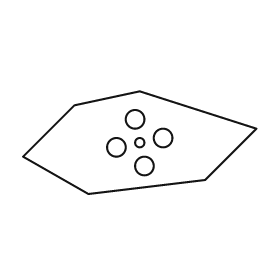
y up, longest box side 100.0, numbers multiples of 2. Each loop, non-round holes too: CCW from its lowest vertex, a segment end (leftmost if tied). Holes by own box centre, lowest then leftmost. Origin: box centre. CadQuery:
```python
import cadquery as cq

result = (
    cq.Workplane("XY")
    .moveTo(-22.0, -22.0)
    .lineTo(28.0, -16.0)
    .lineTo(50.0, 6.0)
    .lineTo(0.0, 22.0)
    .lineTo(-28.0, 16.0)
    .lineTo(-50.0, -6.0)
    .close()
    .moveTo(2.0, -10.0)
    .circle(4.0)
    .moveTo(-10.0, -2.0)
    .circle(4.0)
    .moveTo(0.0, 0.0)
    .circle(2.0)
    .moveTo(10.0, 2.0)
    .circle(4.0)
    .moveTo(-2.0, 10.0)
    .circle(4.0)
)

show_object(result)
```